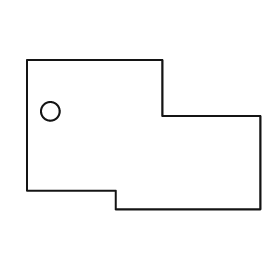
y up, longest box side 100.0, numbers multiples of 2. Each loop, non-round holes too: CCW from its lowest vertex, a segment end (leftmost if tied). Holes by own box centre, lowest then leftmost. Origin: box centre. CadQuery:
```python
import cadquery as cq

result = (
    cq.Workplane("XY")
    .moveTo(-12.0, -32.0)
    .lineTo(50.0, -32.0)
    .lineTo(50.0, 8.0)
    .lineTo(8.0, 8.0)
    .lineTo(8.0, 32.0)
    .lineTo(-50.0, 32.0)
    .lineTo(-50.0, -24.0)
    .lineTo(-12.0, -24.0)
    .close()
    .moveTo(-40.0, 10.0)
    .circle(4.0)
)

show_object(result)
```